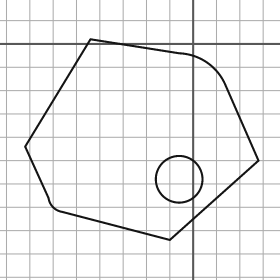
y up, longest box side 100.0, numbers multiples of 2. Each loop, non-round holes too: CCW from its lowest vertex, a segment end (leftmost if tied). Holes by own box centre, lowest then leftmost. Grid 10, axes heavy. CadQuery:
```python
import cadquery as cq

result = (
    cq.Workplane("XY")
    .moveTo(-10.0, -84.0)
    .lineTo(28.0, -50.0)
    .lineTo(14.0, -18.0)
    .threePointArc((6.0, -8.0), (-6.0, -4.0))
    .lineTo(-44.0, 2.0)
    .lineTo(-72.0, -44.0)
    .lineTo(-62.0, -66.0)
    .threePointArc((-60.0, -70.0), (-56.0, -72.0))
    .close()
    .moveTo(-6.0, -58.0)
    .circle(10.0)
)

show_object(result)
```